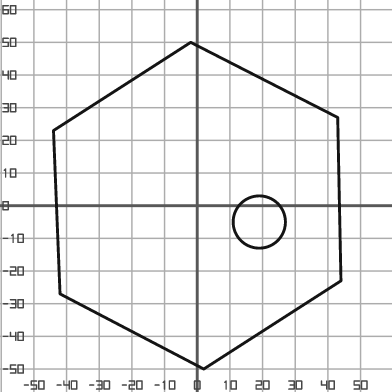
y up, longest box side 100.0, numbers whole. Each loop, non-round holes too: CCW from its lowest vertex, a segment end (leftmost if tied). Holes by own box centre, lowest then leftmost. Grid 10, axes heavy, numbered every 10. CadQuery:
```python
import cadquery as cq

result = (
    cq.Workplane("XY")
    .moveTo(2.0, -50.0)
    .lineTo(44.0, -23.0)
    .lineTo(43.0, 27.0)
    .lineTo(-2.0, 50.0)
    .lineTo(-44.0, 23.0)
    .lineTo(-42.0, -27.0)
    .close()
    .moveTo(19.0, -5.0)
    .circle(8.0)
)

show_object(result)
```